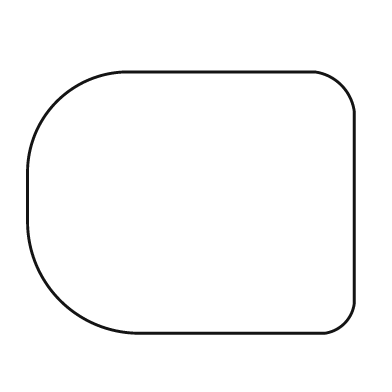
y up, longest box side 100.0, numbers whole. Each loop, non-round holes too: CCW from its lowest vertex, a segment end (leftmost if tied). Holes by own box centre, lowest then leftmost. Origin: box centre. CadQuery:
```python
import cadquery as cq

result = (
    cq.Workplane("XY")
    .moveTo(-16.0, -40.0)
    .lineTo(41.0, -40.0)
    .threePointArc((47.0, -37.0), (50.0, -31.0))
    .lineTo(50.0, 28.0)
    .threePointArc((46.0, 36.0), (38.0, 40.0))
    .lineTo(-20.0, 40.0)
    .threePointArc((-41.0, 31.0), (-50.0, 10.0))
    .lineTo(-50.0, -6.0)
    .threePointArc((-40.0, -30.0), (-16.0, -40.0))
    .close()
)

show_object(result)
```